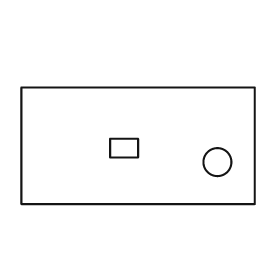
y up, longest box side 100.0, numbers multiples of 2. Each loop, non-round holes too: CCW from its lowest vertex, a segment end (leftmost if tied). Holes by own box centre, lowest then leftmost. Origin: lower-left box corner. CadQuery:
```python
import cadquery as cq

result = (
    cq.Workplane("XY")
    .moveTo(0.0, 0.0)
    .lineTo(100.0, 0.0)
    .lineTo(100.0, 50.0)
    .lineTo(0.0, 50.0)
    .close()
    .moveTo(84.0, 18.0)
    .circle(6.0)
    .moveTo(38.0, 20.0)
    .lineTo(50.0, 20.0)
    .lineTo(50.0, 28.0)
    .lineTo(38.0, 28.0)
    .close()
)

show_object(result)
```